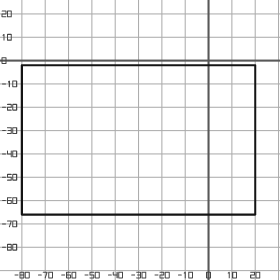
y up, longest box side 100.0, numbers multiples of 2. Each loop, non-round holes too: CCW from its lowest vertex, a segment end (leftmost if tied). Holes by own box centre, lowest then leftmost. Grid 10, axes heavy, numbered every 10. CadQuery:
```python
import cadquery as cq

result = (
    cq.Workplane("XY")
    .moveTo(-80.0, -66.0)
    .lineTo(20.0, -66.0)
    .lineTo(20.0, -2.0)
    .lineTo(-80.0, -2.0)
    .close()
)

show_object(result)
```